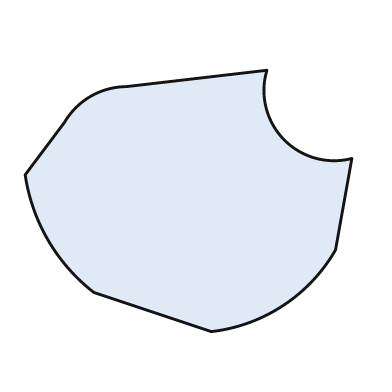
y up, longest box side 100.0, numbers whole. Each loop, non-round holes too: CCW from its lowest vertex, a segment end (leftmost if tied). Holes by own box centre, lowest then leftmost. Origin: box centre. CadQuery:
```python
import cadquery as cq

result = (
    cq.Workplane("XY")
    .moveTo(7.0, -40.0)
    .threePointArc((29.0, -32.0), (45.0, -15.0))
    .lineTo(50.0, 13.0)
    .threePointArc((29.0, 19.0), (24.0, 40.0))
    .lineTo(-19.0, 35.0)
    .threePointArc((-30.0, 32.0), (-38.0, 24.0))
    .lineTo(-50.0, 8.0)
    .threePointArc((-43.0, -12.0), (-29.0, -28.0))
    .close()
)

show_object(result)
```